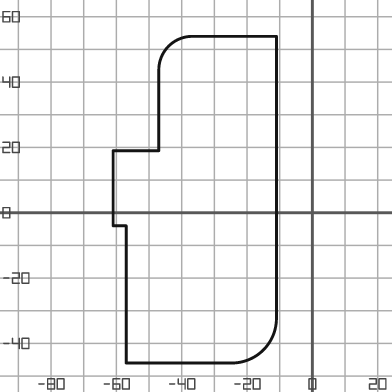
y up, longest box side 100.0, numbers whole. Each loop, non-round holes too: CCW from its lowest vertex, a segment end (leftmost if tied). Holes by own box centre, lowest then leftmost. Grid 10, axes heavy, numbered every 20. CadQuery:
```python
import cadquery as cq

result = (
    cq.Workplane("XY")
    .moveTo(-57.0, -46.0)
    .lineTo(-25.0, -46.0)
    .threePointArc((-15.0, -42.0), (-11.0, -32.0))
    .lineTo(-11.0, 54.0)
    .lineTo(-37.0, 54.0)
    .threePointArc((-44.0, 51.0), (-47.0, 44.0))
    .lineTo(-47.0, 19.0)
    .lineTo(-61.0, 19.0)
    .lineTo(-61.0, -4.0)
    .lineTo(-57.0, -4.0)
    .close()
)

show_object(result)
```